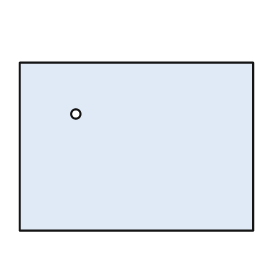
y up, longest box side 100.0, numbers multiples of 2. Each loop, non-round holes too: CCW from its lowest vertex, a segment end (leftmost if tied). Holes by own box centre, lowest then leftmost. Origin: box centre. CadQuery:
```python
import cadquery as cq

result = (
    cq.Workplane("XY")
    .moveTo(-50.0, -36.0)
    .lineTo(50.0, -36.0)
    .lineTo(50.0, 36.0)
    .lineTo(-50.0, 36.0)
    .close()
    .moveTo(-26.0, 14.0)
    .circle(2.0)
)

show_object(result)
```